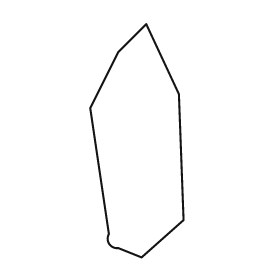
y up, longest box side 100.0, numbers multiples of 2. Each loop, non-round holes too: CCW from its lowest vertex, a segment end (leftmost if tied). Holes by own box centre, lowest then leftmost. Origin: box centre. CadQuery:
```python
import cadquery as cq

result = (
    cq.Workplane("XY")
    .moveTo(2.0, -50.0)
    .lineTo(20.0, -34.0)
    .lineTo(18.0, 20.0)
    .lineTo(4.0, 50.0)
    .lineTo(-8.0, 38.0)
    .lineTo(-20.0, 14.0)
    .lineTo(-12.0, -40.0)
    .threePointArc((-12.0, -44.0), (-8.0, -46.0))
    .close()
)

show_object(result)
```